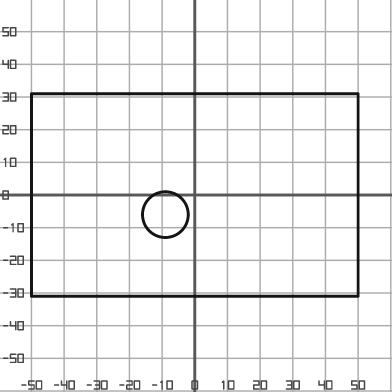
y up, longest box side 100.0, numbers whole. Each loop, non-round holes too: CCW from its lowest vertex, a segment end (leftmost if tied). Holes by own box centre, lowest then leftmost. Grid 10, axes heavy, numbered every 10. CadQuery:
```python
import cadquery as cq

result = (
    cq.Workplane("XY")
    .moveTo(-50.0, -31.0)
    .lineTo(50.0, -31.0)
    .lineTo(50.0, 31.0)
    .lineTo(-50.0, 31.0)
    .close()
    .moveTo(-9.0, -6.0)
    .circle(7.0)
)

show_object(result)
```